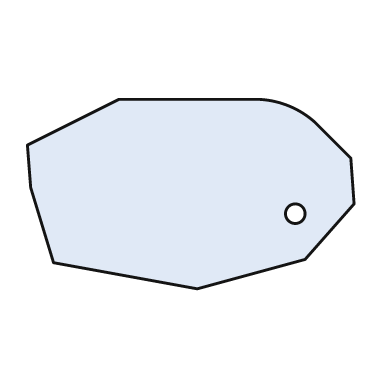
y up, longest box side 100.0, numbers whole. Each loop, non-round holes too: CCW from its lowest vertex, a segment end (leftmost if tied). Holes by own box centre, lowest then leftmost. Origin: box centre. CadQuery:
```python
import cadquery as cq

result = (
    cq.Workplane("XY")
    .moveTo(2.0, -29.0)
    .lineTo(35.0, -20.0)
    .lineTo(50.0, -3.0)
    .lineTo(49.0, 11.0)
    .lineTo(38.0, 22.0)
    .threePointArc((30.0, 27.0), (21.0, 29.0))
    .lineTo(-22.0, 29.0)
    .lineTo(-50.0, 15.0)
    .lineTo(-49.0, 2.0)
    .lineTo(-42.0, -21.0)
    .close()
    .moveTo(32.0, -6.0)
    .circle(3.0)
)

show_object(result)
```